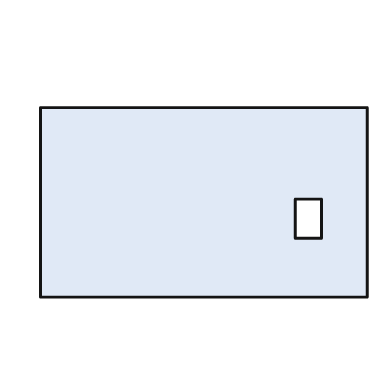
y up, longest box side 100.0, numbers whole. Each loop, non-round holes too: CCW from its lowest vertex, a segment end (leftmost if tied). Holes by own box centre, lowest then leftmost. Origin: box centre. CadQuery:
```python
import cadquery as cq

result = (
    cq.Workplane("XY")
    .moveTo(-50.0, -29.0)
    .lineTo(50.0, -29.0)
    .lineTo(50.0, 29.0)
    .lineTo(-50.0, 29.0)
    .close()
    .moveTo(28.0, -11.0)
    .lineTo(36.0, -11.0)
    .lineTo(36.0, 1.0)
    .lineTo(28.0, 1.0)
    .close()
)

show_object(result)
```